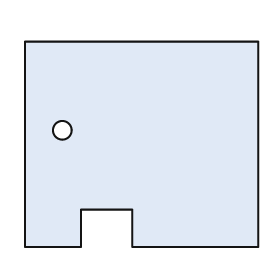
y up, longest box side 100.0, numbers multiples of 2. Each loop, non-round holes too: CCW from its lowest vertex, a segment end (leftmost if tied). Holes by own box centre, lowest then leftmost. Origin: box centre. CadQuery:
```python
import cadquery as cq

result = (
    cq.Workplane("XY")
    .moveTo(-50.0, -44.0)
    .lineTo(-26.0, -44.0)
    .lineTo(-26.0, -28.0)
    .lineTo(-4.0, -28.0)
    .lineTo(-4.0, -44.0)
    .lineTo(50.0, -44.0)
    .lineTo(50.0, 44.0)
    .lineTo(-50.0, 44.0)
    .close()
    .moveTo(-34.0, 6.0)
    .circle(4.0)
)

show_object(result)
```